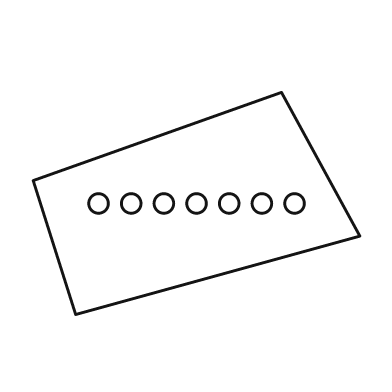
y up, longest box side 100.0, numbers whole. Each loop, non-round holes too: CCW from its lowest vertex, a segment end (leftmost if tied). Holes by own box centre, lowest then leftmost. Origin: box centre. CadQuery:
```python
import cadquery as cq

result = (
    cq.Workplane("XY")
    .moveTo(-37.0, -34.0)
    .lineTo(50.0, -10.0)
    .lineTo(26.0, 34.0)
    .lineTo(-50.0, 7.0)
    .close()
    .moveTo(-30.0, 0.0)
    .circle(3.0)
    .moveTo(-20.0, 0.0)
    .circle(3.0)
    .moveTo(-10.0, 0.0)
    .circle(3.0)
    .moveTo(0.0, 0.0)
    .circle(3.0)
    .moveTo(10.0, 0.0)
    .circle(3.0)
    .moveTo(20.0, 0.0)
    .circle(3.0)
    .moveTo(30.0, 0.0)
    .circle(3.0)
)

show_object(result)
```